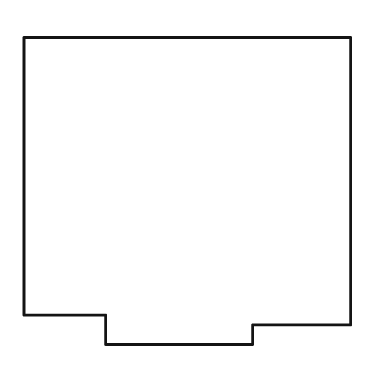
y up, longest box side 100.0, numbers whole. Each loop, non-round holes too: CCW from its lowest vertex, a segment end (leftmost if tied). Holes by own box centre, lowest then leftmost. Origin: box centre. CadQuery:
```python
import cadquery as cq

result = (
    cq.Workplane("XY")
    .moveTo(-25.0, -47.0)
    .lineTo(20.0, -47.0)
    .lineTo(20.0, -41.0)
    .lineTo(50.0, -41.0)
    .lineTo(50.0, 47.0)
    .lineTo(-50.0, 47.0)
    .lineTo(-50.0, -38.0)
    .lineTo(-25.0, -38.0)
    .close()
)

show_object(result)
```